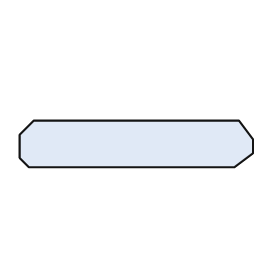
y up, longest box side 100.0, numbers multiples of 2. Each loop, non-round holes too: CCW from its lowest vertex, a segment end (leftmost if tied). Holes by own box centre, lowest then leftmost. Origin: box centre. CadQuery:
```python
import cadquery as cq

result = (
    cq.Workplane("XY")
    .moveTo(-46.0, -10.0)
    .lineTo(42.0, -10.0)
    .lineTo(50.0, -4.0)
    .lineTo(50.0, 2.0)
    .lineTo(44.0, 10.0)
    .lineTo(-44.0, 10.0)
    .lineTo(-50.0, 4.0)
    .lineTo(-50.0, -6.0)
    .close()
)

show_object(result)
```